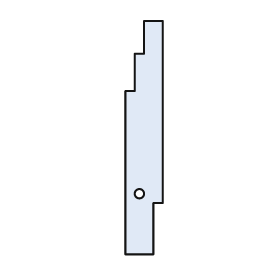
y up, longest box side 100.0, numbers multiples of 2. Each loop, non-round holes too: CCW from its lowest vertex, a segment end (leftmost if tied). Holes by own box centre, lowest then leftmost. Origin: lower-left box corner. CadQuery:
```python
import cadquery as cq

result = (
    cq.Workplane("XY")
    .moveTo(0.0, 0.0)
    .lineTo(12.0, 0.0)
    .lineTo(12.0, 22.0)
    .lineTo(16.0, 22.0)
    .lineTo(16.0, 100.0)
    .lineTo(8.0, 100.0)
    .lineTo(8.0, 86.0)
    .lineTo(4.0, 86.0)
    .lineTo(4.0, 70.0)
    .lineTo(0.0, 70.0)
    .close()
    .moveTo(6.0, 26.0)
    .circle(2.0)
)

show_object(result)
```